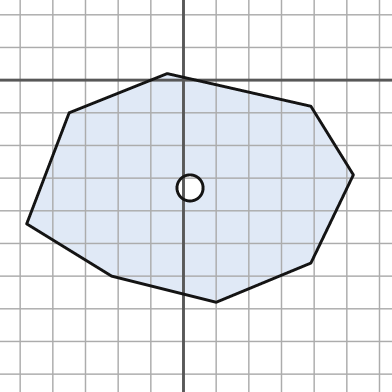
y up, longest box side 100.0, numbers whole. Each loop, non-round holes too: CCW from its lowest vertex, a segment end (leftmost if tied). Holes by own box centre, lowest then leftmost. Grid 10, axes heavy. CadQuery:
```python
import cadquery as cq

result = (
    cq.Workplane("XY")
    .moveTo(10.0, -68.0)
    .lineTo(39.0, -56.0)
    .lineTo(52.0, -29.0)
    .lineTo(39.0, -8.0)
    .lineTo(-5.0, 2.0)
    .lineTo(-35.0, -10.0)
    .lineTo(-48.0, -44.0)
    .lineTo(-22.0, -60.0)
    .close()
    .moveTo(2.0, -33.0)
    .circle(4.0)
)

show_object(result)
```